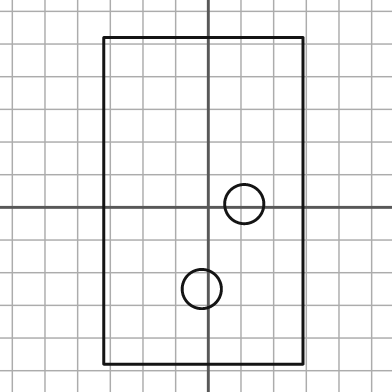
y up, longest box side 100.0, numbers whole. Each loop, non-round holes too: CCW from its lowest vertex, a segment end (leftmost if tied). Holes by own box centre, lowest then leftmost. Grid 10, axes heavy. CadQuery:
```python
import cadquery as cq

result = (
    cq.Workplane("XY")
    .moveTo(-32.0, -48.0)
    .lineTo(29.0, -48.0)
    .lineTo(29.0, 52.0)
    .lineTo(-32.0, 52.0)
    .close()
    .moveTo(-2.0, -25.0)
    .circle(6.0)
    .moveTo(11.0, 1.0)
    .circle(6.0)
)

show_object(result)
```